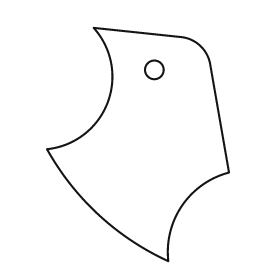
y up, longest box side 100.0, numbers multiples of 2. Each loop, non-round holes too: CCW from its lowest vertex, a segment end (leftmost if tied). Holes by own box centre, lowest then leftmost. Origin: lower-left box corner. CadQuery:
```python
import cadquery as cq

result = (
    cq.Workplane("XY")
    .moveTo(52.0, 0.0)
    .threePointArc((58.0, 24.0), (78.0, 38.0))
    .lineTo(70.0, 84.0)
    .threePointArc((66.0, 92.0), (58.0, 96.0))
    .lineTo(20.0, 100.0)
    .threePointArc((26.0, 68.0), (0.0, 48.0))
    .threePointArc((22.0, 20.0), (52.0, 0.0))
    .close()
    .moveTo(46.0, 82.0)
    .circle(4.0)
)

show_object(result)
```